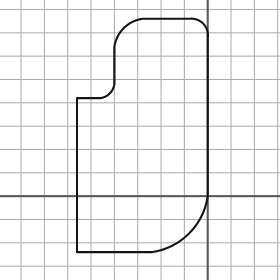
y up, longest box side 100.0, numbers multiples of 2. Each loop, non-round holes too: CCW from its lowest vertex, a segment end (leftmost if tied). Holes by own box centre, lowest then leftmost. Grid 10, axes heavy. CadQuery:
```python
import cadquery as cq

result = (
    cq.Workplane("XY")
    .moveTo(-56.0, -24.0)
    .lineTo(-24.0, -24.0)
    .threePointArc((-8.0, -16.0), (0.0, 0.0))
    .lineTo(0.0, 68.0)
    .threePointArc((-2.0, 74.0), (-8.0, 76.0))
    .lineTo(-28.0, 76.0)
    .threePointArc((-36.0, 72.0), (-40.0, 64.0))
    .lineTo(-40.0, 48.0)
    .threePointArc((-42.0, 44.0), (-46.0, 42.0))
    .lineTo(-56.0, 42.0)
    .close()
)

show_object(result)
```